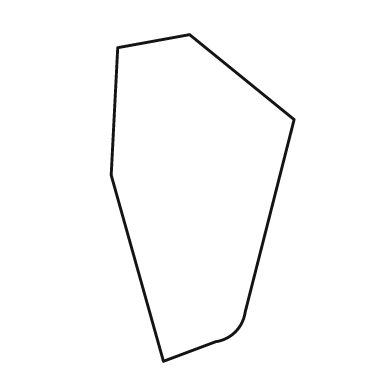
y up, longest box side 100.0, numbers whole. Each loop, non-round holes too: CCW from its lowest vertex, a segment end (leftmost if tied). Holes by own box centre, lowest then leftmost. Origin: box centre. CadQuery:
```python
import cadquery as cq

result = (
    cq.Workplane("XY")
    .moveTo(-12.0, -50.0)
    .lineTo(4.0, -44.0)
    .threePointArc((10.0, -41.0), (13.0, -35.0))
    .lineTo(28.0, 24.0)
    .lineTo(-4.0, 50.0)
    .lineTo(-26.0, 46.0)
    .lineTo(-28.0, 7.0)
    .close()
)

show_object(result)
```